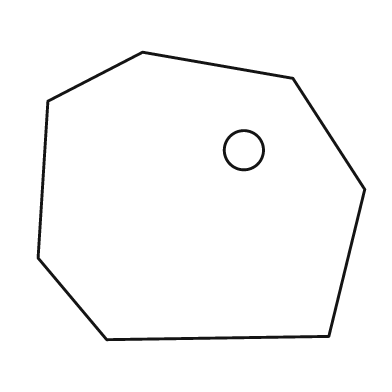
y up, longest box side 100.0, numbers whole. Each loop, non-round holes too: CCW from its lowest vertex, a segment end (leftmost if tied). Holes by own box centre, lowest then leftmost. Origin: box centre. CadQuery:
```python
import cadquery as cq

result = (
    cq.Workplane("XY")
    .moveTo(-29.0, -44.0)
    .lineTo(39.0, -43.0)
    .lineTo(50.0, 2.0)
    .lineTo(28.0, 36.0)
    .lineTo(-18.0, 44.0)
    .lineTo(-47.0, 29.0)
    .lineTo(-50.0, -19.0)
    .close()
    .moveTo(13.0, 14.0)
    .circle(6.0)
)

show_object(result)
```